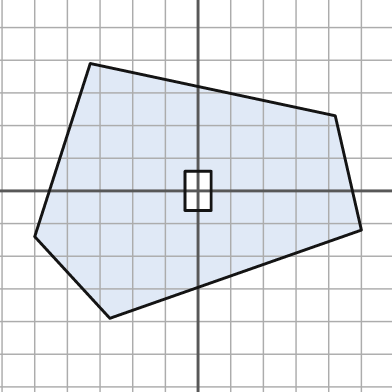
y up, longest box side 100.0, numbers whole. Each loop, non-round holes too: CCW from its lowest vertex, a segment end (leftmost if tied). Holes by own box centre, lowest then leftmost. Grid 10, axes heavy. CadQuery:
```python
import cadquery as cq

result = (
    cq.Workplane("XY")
    .moveTo(-27.0, -39.0)
    .lineTo(50.0, -12.0)
    .lineTo(42.0, 23.0)
    .lineTo(-33.0, 39.0)
    .lineTo(-50.0, -14.0)
    .close()
    .moveTo(-4.0, -6.0)
    .lineTo(4.0, -6.0)
    .lineTo(4.0, 6.0)
    .lineTo(-4.0, 6.0)
    .close()
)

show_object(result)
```